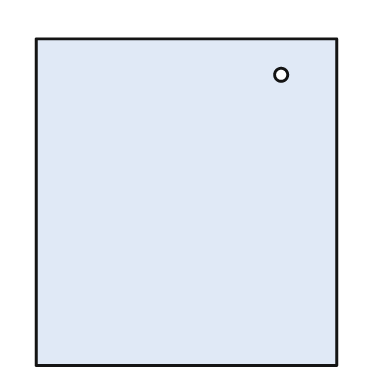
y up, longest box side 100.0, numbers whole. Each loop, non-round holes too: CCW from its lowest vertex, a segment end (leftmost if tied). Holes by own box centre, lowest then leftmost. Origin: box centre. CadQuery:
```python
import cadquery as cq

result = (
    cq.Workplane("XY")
    .moveTo(-46.0, -50.0)
    .lineTo(46.0, -50.0)
    .lineTo(46.0, 50.0)
    .lineTo(-46.0, 50.0)
    .close()
    .moveTo(29.0, 39.0)
    .circle(2.0)
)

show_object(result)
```